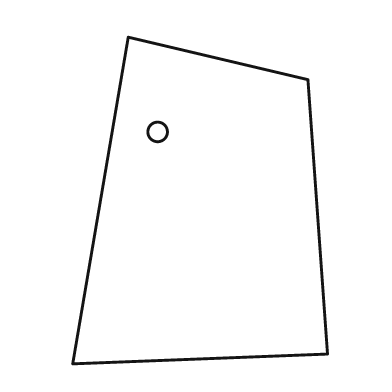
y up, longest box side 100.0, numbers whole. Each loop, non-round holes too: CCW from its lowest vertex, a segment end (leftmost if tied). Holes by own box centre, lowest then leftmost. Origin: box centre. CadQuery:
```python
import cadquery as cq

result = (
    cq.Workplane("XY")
    .moveTo(-39.0, -50.0)
    .lineTo(39.0, -47.0)
    .lineTo(33.0, 37.0)
    .lineTo(-22.0, 50.0)
    .close()
    .moveTo(-13.0, 21.0)
    .circle(3.0)
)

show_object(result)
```